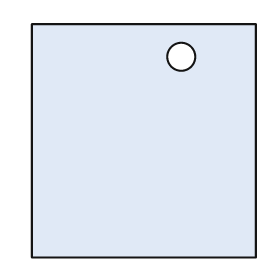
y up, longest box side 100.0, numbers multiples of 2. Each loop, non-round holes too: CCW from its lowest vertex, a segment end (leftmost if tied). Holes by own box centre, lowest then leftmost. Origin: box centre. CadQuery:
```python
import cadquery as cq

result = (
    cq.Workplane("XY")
    .moveTo(-48.0, -50.0)
    .lineTo(48.0, -50.0)
    .lineTo(48.0, 50.0)
    .lineTo(-48.0, 50.0)
    .close()
    .moveTo(16.0, 36.0)
    .circle(6.0)
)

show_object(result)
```